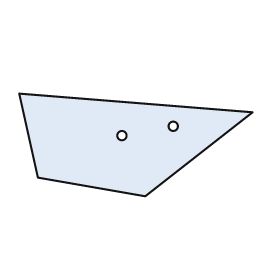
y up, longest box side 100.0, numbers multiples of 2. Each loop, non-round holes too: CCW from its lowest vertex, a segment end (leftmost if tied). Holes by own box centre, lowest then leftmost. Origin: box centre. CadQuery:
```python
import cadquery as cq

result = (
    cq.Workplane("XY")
    .moveTo(4.0, -22.0)
    .lineTo(50.0, 14.0)
    .lineTo(-50.0, 22.0)
    .lineTo(-42.0, -14.0)
    .close()
    .moveTo(-6.0, 4.0)
    .circle(2.0)
    .moveTo(16.0, 8.0)
    .circle(2.0)
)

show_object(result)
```